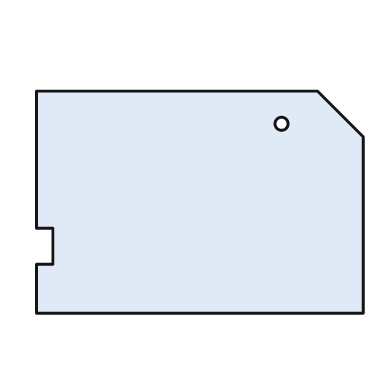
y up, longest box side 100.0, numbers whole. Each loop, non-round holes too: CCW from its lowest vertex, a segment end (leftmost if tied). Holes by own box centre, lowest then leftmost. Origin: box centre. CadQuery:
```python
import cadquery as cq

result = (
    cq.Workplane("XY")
    .moveTo(-50.0, -34.0)
    .lineTo(50.0, -34.0)
    .lineTo(50.0, 20.0)
    .lineTo(36.0, 34.0)
    .lineTo(-50.0, 34.0)
    .lineTo(-50.0, -8.0)
    .lineTo(-45.0, -8.0)
    .lineTo(-45.0, -19.0)
    .lineTo(-50.0, -19.0)
    .close()
    .moveTo(25.0, 24.0)
    .circle(2.0)
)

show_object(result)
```